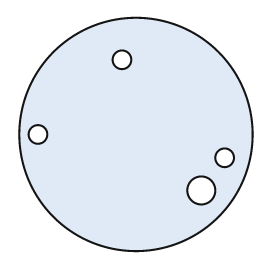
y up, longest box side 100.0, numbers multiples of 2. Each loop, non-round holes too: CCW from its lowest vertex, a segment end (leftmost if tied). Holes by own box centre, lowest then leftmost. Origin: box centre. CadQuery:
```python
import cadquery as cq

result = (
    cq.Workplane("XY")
    .moveTo(0.0, 0.0)
    .circle(50.0)
    .moveTo(28.0, -24.0)
    .circle(6.0)
    .moveTo(38.0, -10.0)
    .circle(4.0)
    .moveTo(-42.0, 0.0)
    .circle(4.0)
    .moveTo(-6.0, 32.0)
    .circle(4.0)
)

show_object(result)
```